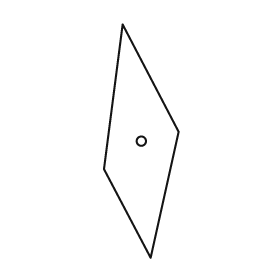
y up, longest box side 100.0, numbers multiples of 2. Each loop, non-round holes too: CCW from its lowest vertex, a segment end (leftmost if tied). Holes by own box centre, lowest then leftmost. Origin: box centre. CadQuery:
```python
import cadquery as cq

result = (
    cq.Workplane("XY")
    .moveTo(4.0, -50.0)
    .lineTo(16.0, 4.0)
    .lineTo(-8.0, 50.0)
    .lineTo(-16.0, -12.0)
    .close()
    .moveTo(0.0, 0.0)
    .circle(2.0)
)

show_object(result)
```